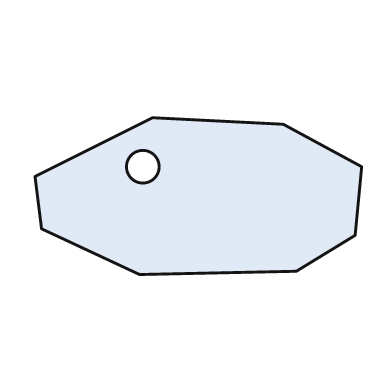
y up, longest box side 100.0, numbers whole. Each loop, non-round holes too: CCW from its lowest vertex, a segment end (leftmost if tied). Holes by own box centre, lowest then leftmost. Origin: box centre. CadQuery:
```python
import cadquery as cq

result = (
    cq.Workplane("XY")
    .moveTo(-18.0, -24.0)
    .lineTo(30.0, -23.0)
    .lineTo(48.0, -12.0)
    .lineTo(50.0, 9.0)
    .lineTo(26.0, 22.0)
    .lineTo(-14.0, 24.0)
    .lineTo(-50.0, 6.0)
    .lineTo(-48.0, -10.0)
    .close()
    .moveTo(-17.0, 9.0)
    .circle(5.0)
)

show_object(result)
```